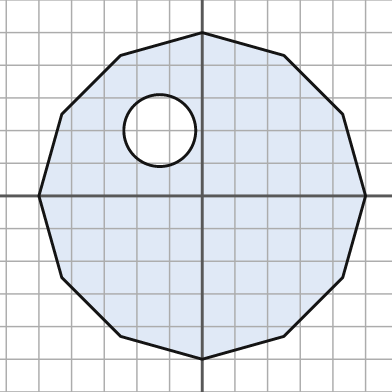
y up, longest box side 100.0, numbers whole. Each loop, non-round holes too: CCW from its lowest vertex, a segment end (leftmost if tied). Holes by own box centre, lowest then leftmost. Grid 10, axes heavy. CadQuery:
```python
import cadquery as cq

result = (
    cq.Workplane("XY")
    .moveTo(0.0, -50.0)
    .lineTo(25.0, -43.0)
    .lineTo(43.0, -25.0)
    .lineTo(50.0, 0.0)
    .lineTo(43.0, 25.0)
    .lineTo(25.0, 43.0)
    .lineTo(0.0, 50.0)
    .lineTo(-25.0, 43.0)
    .lineTo(-43.0, 25.0)
    .lineTo(-50.0, 0.0)
    .lineTo(-43.0, -25.0)
    .lineTo(-25.0, -43.0)
    .close()
    .moveTo(-13.0, 20.0)
    .circle(11.0)
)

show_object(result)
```